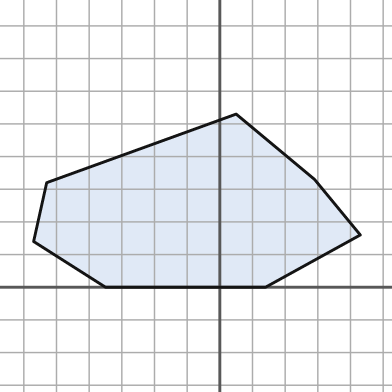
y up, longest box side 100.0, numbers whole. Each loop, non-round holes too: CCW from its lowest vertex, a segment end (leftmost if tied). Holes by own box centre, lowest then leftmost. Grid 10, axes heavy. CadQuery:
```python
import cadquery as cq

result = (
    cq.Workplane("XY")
    .moveTo(-35.0, 0.0)
    .lineTo(14.0, 0.0)
    .lineTo(43.0, 16.0)
    .lineTo(29.0, 33.0)
    .lineTo(5.0, 53.0)
    .lineTo(-53.0, 32.0)
    .lineTo(-57.0, 14.0)
    .close()
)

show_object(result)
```